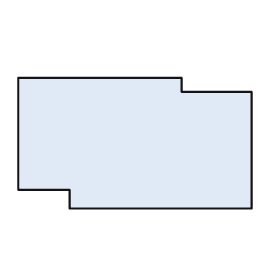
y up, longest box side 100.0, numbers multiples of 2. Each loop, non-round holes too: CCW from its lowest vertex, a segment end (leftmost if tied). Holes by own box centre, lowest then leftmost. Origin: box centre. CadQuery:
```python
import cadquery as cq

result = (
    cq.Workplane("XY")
    .moveTo(-28.0, -28.0)
    .lineTo(50.0, -28.0)
    .lineTo(50.0, 22.0)
    .lineTo(20.0, 22.0)
    .lineTo(20.0, 28.0)
    .lineTo(-50.0, 28.0)
    .lineTo(-50.0, -20.0)
    .lineTo(-28.0, -20.0)
    .close()
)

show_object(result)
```